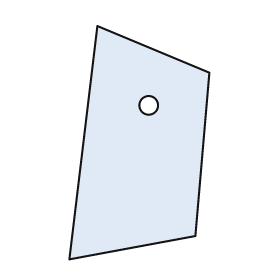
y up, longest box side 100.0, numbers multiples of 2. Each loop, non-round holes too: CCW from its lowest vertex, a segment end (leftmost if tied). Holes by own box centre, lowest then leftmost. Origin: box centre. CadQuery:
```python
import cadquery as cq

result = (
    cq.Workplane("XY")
    .moveTo(-30.0, -50.0)
    .lineTo(24.0, -40.0)
    .lineTo(30.0, 30.0)
    .lineTo(-18.0, 50.0)
    .close()
    .moveTo(4.0, 16.0)
    .circle(4.0)
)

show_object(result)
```